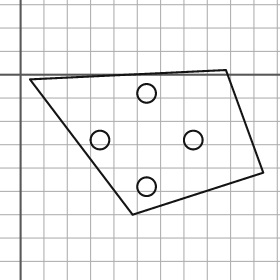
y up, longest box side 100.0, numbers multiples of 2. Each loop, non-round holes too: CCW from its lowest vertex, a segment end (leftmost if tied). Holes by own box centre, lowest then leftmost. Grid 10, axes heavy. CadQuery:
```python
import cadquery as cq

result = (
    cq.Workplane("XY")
    .moveTo(48.0, -60.0)
    .lineTo(104.0, -42.0)
    .lineTo(88.0, 2.0)
    .lineTo(4.0, -2.0)
    .close()
    .moveTo(54.0, -48.0)
    .circle(4.0)
    .moveTo(34.0, -28.0)
    .circle(4.0)
    .moveTo(74.0, -28.0)
    .circle(4.0)
    .moveTo(54.0, -8.0)
    .circle(4.0)
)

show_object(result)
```